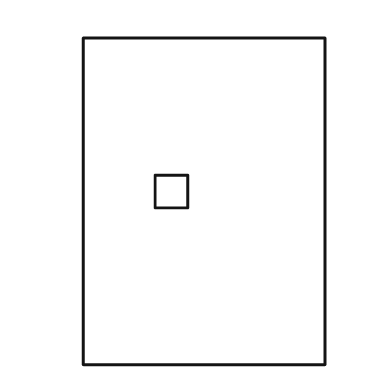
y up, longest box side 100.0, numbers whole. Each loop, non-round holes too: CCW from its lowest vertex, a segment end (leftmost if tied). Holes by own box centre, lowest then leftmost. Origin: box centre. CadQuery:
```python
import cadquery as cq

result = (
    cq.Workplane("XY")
    .moveTo(-37.0, -50.0)
    .lineTo(37.0, -50.0)
    .lineTo(37.0, 50.0)
    .lineTo(-37.0, 50.0)
    .close()
    .moveTo(-15.0, -2.0)
    .lineTo(-5.0, -2.0)
    .lineTo(-5.0, 8.0)
    .lineTo(-15.0, 8.0)
    .close()
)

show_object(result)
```